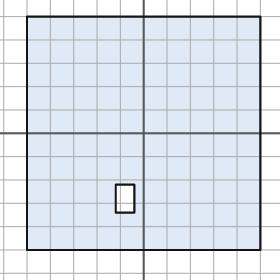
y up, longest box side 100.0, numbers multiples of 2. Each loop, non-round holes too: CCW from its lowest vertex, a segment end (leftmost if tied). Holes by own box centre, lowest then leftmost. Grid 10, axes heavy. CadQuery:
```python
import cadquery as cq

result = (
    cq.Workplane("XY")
    .moveTo(-50.0, -50.0)
    .lineTo(50.0, -50.0)
    .lineTo(50.0, 50.0)
    .lineTo(-50.0, 50.0)
    .close()
    .moveTo(-12.0, -34.0)
    .lineTo(-4.0, -34.0)
    .lineTo(-4.0, -22.0)
    .lineTo(-12.0, -22.0)
    .close()
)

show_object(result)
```